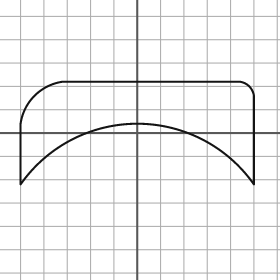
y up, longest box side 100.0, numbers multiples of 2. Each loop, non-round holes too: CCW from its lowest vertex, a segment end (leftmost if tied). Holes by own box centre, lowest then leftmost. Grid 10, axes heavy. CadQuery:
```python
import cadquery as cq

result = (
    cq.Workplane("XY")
    .moveTo(-50.0, -22.0)
    .threePointArc((0.0, 4.0), (50.0, -22.0))
    .lineTo(50.0, 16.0)
    .threePointArc((48.0, 20.0), (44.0, 22.0))
    .lineTo(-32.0, 22.0)
    .threePointArc((-44.0, 16.0), (-50.0, 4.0))
    .close()
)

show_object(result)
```